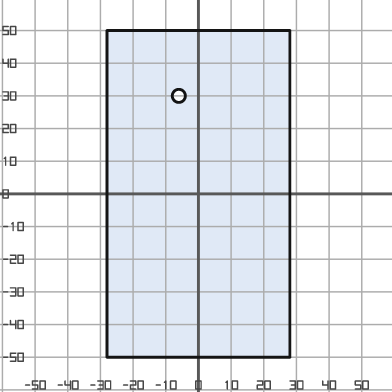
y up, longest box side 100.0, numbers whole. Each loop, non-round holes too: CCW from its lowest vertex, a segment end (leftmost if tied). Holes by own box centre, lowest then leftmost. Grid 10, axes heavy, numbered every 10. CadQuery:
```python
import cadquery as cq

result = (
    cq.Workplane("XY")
    .moveTo(-28.0, -50.0)
    .lineTo(28.0, -50.0)
    .lineTo(28.0, 50.0)
    .lineTo(-28.0, 50.0)
    .close()
    .moveTo(-6.0, 30.0)
    .circle(2.0)
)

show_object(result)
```